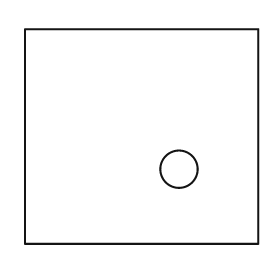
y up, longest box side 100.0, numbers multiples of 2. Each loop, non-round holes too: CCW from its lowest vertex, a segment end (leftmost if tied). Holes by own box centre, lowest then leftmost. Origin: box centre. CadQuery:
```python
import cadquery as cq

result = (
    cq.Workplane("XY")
    .moveTo(-50.0, -46.0)
    .lineTo(50.0, -46.0)
    .lineTo(50.0, 46.0)
    .lineTo(-50.0, 46.0)
    .close()
    .moveTo(16.0, -14.0)
    .circle(8.0)
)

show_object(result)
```